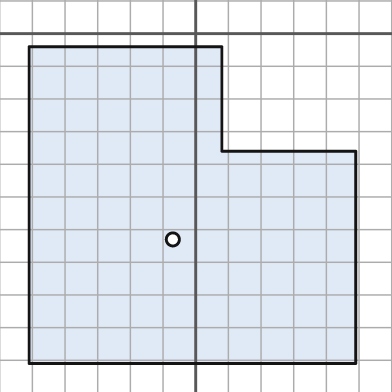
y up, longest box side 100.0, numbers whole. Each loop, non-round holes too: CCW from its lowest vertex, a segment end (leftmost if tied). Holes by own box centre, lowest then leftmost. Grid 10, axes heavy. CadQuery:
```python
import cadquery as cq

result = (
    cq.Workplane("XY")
    .moveTo(-51.0, -101.0)
    .lineTo(49.0, -101.0)
    .lineTo(49.0, -36.0)
    .lineTo(8.0, -36.0)
    .lineTo(8.0, -4.0)
    .lineTo(-51.0, -4.0)
    .close()
    .moveTo(-7.0, -63.0)
    .circle(2.0)
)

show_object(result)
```